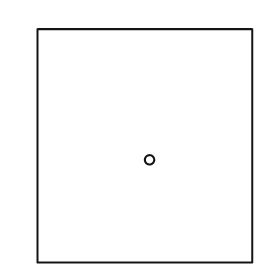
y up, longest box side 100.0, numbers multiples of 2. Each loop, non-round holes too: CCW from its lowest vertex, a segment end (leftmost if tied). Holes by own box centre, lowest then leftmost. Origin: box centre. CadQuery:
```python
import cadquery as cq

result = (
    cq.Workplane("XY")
    .moveTo(-46.0, -50.0)
    .lineTo(46.0, -50.0)
    .lineTo(46.0, 50.0)
    .lineTo(-46.0, 50.0)
    .close()
    .moveTo(2.0, -6.0)
    .circle(2.0)
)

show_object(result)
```